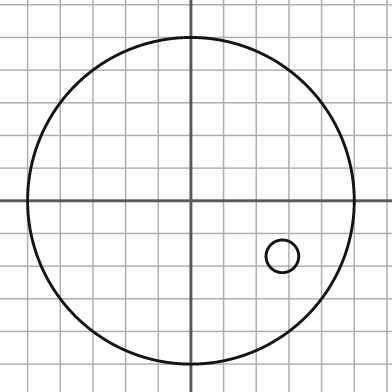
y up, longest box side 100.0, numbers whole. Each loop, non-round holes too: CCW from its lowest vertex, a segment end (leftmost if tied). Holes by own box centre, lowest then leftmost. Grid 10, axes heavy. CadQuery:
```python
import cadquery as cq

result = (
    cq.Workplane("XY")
    .moveTo(0.0, 0.0)
    .circle(50.0)
    .moveTo(28.0, -17.0)
    .circle(5.0)
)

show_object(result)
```